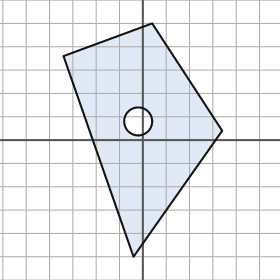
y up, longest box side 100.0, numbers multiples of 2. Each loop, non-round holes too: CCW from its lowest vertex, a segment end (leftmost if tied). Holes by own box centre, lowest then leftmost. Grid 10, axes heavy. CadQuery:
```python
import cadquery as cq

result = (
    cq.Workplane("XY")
    .moveTo(-4.0, -50.0)
    .lineTo(34.0, 4.0)
    .lineTo(4.0, 50.0)
    .lineTo(-34.0, 36.0)
    .close()
    .moveTo(-2.0, 8.0)
    .circle(6.0)
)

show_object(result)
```